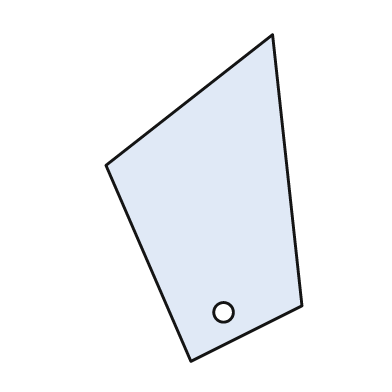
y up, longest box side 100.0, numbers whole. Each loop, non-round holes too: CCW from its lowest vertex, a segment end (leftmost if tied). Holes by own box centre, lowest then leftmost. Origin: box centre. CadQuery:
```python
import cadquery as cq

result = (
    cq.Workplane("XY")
    .moveTo(-4.0, -50.0)
    .lineTo(30.0, -33.0)
    .lineTo(21.0, 50.0)
    .lineTo(-30.0, 10.0)
    .close()
    .moveTo(6.0, -35.0)
    .circle(3.0)
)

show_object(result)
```